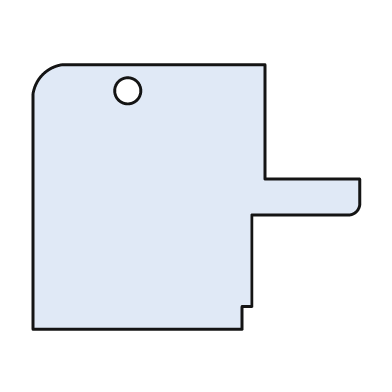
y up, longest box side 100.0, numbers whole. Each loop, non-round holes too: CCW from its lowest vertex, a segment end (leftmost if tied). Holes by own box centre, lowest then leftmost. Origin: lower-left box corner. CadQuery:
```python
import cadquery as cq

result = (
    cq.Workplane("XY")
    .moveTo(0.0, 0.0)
    .lineTo(64.0, 0.0)
    .lineTo(64.0, 7.0)
    .lineTo(67.0, 7.0)
    .lineTo(67.0, 35.0)
    .lineTo(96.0, 35.0)
    .threePointArc((99.0, 36.0), (100.0, 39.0))
    .lineTo(100.0, 46.0)
    .lineTo(71.0, 46.0)
    .lineTo(71.0, 81.0)
    .lineTo(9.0, 81.0)
    .threePointArc((3.0, 78.0), (0.0, 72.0))
    .close()
    .moveTo(29.0, 73.0)
    .circle(4.0)
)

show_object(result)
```